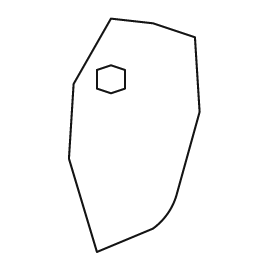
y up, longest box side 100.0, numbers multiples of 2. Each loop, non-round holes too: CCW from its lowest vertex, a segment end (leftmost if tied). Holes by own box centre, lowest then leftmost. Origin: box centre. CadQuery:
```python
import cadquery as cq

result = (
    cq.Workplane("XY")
    .moveTo(-16.0, -50.0)
    .lineTo(8.0, -40.0)
    .threePointArc((14.0, -34.0), (18.0, -26.0))
    .lineTo(28.0, 10.0)
    .lineTo(26.0, 42.0)
    .lineTo(8.0, 48.0)
    .lineTo(-10.0, 50.0)
    .lineTo(-26.0, 22.0)
    .lineTo(-28.0, -10.0)
    .close()
    .moveTo(-10.0, 18.0)
    .lineTo(-4.0, 20.0)
    .lineTo(-4.0, 28.0)
    .lineTo(-10.0, 30.0)
    .lineTo(-16.0, 28.0)
    .lineTo(-16.0, 20.0)
    .close()
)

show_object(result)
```